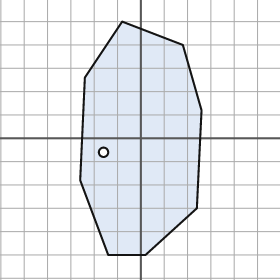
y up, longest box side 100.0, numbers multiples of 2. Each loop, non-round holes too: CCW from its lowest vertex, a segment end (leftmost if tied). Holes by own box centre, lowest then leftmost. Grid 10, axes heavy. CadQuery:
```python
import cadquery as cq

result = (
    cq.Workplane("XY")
    .moveTo(-14.0, -50.0)
    .lineTo(2.0, -50.0)
    .lineTo(24.0, -30.0)
    .lineTo(26.0, 12.0)
    .lineTo(18.0, 40.0)
    .lineTo(-8.0, 50.0)
    .lineTo(-24.0, 26.0)
    .lineTo(-26.0, -18.0)
    .close()
    .moveTo(-16.0, -6.0)
    .circle(2.0)
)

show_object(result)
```